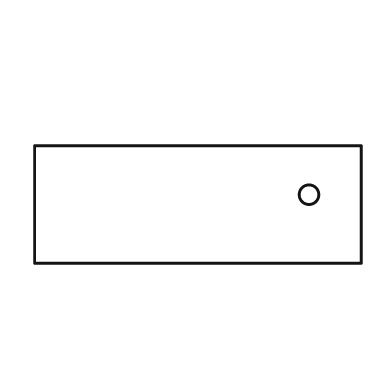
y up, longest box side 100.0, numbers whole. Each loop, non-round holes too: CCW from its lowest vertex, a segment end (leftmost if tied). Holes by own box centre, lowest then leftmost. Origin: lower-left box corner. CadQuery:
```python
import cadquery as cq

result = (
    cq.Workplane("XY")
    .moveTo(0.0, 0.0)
    .lineTo(100.0, 0.0)
    .lineTo(100.0, 36.0)
    .lineTo(0.0, 36.0)
    .close()
    .moveTo(84.0, 21.0)
    .circle(3.0)
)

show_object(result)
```